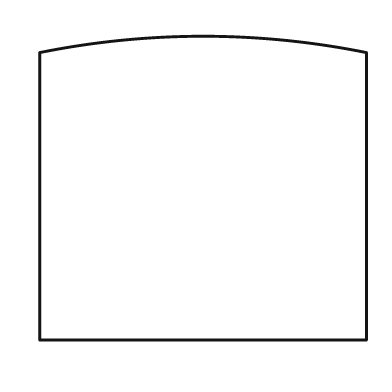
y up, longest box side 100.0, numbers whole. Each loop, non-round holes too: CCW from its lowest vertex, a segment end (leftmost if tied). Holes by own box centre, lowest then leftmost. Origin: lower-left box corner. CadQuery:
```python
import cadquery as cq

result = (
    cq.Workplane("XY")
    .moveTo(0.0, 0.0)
    .lineTo(100.0, 0.0)
    .lineTo(100.0, 88.0)
    .threePointArc((50.0, 93.0), (0.0, 88.0))
    .close()
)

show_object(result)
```